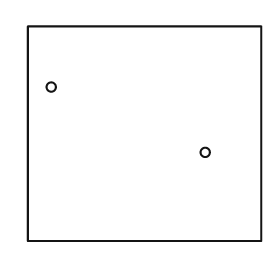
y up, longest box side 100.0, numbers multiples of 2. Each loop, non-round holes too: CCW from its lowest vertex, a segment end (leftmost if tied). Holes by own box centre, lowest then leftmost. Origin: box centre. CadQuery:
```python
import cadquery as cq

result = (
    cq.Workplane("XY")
    .moveTo(-50.0, -46.0)
    .lineTo(50.0, -46.0)
    .lineTo(50.0, 46.0)
    .lineTo(-50.0, 46.0)
    .close()
    .moveTo(26.0, -8.0)
    .circle(2.0)
    .moveTo(-40.0, 20.0)
    .circle(2.0)
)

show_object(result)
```